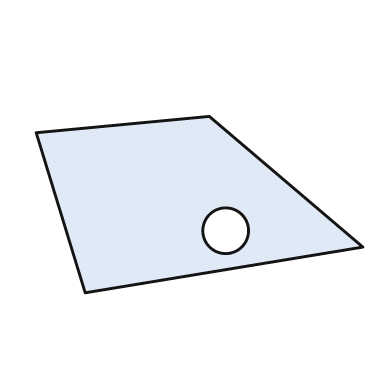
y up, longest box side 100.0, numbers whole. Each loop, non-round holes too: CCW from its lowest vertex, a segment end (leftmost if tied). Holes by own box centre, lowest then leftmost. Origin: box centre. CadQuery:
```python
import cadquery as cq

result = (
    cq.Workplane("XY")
    .moveTo(-35.0, -27.0)
    .lineTo(50.0, -13.0)
    .lineTo(3.0, 27.0)
    .lineTo(-50.0, 22.0)
    .close()
    .moveTo(8.0, -8.0)
    .circle(7.0)
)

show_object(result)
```